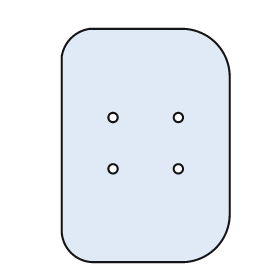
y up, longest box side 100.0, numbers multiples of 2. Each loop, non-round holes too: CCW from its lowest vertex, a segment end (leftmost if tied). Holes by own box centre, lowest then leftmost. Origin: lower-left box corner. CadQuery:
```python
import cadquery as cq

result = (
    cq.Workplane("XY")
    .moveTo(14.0, 0.0)
    .lineTo(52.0, 0.0)
    .threePointArc((66.0, 6.0), (72.0, 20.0))
    .lineTo(72.0, 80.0)
    .threePointArc((66.0, 94.0), (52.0, 100.0))
    .lineTo(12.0, 100.0)
    .threePointArc((4.0, 96.0), (0.0, 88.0))
    .lineTo(0.0, 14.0)
    .threePointArc((4.0, 4.0), (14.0, 0.0))
    .close()
    .moveTo(22.0, 40.0)
    .circle(2.0)
    .moveTo(50.0, 40.0)
    .circle(2.0)
    .moveTo(22.0, 62.0)
    .circle(2.0)
    .moveTo(50.0, 62.0)
    .circle(2.0)
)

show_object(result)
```